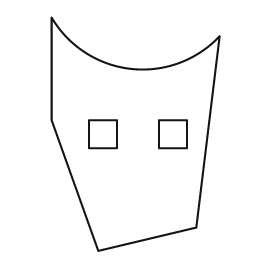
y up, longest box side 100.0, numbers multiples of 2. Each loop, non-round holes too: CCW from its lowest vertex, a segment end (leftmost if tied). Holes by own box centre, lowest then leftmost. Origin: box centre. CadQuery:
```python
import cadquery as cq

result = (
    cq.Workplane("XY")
    .moveTo(-16.0, -50.0)
    .lineTo(26.0, -40.0)
    .lineTo(36.0, 42.0)
    .threePointArc((-2.0, 28.0), (-36.0, 50.0))
    .lineTo(-36.0, 6.0)
    .close()
    .moveTo(-20.0, -6.0)
    .lineTo(-8.0, -6.0)
    .lineTo(-8.0, 6.0)
    .lineTo(-20.0, 6.0)
    .close()
    .moveTo(10.0, -6.0)
    .lineTo(22.0, -6.0)
    .lineTo(22.0, 6.0)
    .lineTo(10.0, 6.0)
    .close()
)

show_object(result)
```